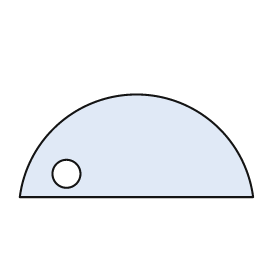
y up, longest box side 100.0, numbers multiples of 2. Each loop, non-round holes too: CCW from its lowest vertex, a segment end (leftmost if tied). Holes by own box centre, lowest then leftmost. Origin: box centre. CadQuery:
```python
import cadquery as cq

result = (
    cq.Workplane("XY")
    .moveTo(-50.0, -22.0)
    .lineTo(50.0, -22.0)
    .threePointArc((0.0, 22.0), (-50.0, -22.0))
    .close()
    .moveTo(-30.0, -12.0)
    .circle(6.0)
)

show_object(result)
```